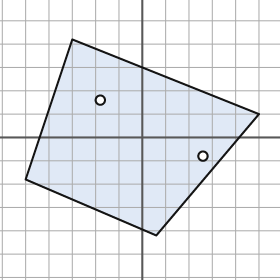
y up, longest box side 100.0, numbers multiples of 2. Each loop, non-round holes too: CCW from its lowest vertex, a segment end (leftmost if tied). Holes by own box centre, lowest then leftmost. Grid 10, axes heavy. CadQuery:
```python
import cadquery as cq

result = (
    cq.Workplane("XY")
    .moveTo(6.0, -42.0)
    .lineTo(50.0, 10.0)
    .lineTo(-30.0, 42.0)
    .lineTo(-50.0, -18.0)
    .close()
    .moveTo(26.0, -8.0)
    .circle(2.0)
    .moveTo(-18.0, 16.0)
    .circle(2.0)
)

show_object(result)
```